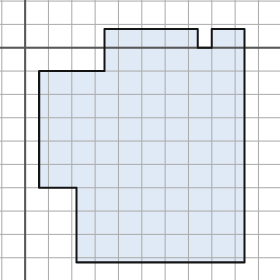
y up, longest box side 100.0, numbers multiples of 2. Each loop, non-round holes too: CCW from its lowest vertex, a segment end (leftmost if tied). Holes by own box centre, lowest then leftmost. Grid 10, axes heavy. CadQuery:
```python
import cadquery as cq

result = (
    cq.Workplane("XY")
    .moveTo(22.0, -92.0)
    .lineTo(94.0, -92.0)
    .lineTo(94.0, 8.0)
    .lineTo(80.0, 8.0)
    .lineTo(80.0, 0.0)
    .lineTo(74.0, 0.0)
    .lineTo(74.0, 8.0)
    .lineTo(34.0, 8.0)
    .lineTo(34.0, -10.0)
    .lineTo(6.0, -10.0)
    .lineTo(6.0, -60.0)
    .lineTo(22.0, -60.0)
    .close()
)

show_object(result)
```